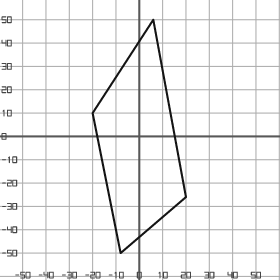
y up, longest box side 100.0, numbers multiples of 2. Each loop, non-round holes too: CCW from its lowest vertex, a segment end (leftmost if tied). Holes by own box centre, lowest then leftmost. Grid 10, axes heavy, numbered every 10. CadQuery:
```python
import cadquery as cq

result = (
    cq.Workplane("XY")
    .moveTo(-8.0, -50.0)
    .lineTo(20.0, -26.0)
    .lineTo(6.0, 50.0)
    .lineTo(-20.0, 10.0)
    .close()
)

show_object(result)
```